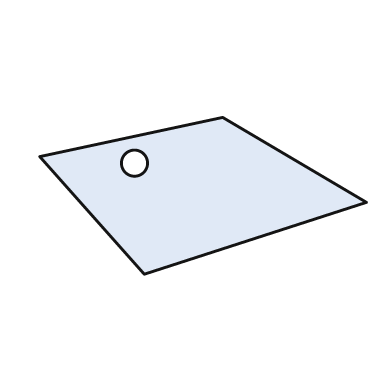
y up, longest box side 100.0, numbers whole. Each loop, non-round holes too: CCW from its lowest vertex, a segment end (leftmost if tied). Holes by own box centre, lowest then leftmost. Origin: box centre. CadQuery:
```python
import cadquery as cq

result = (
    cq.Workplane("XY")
    .moveTo(-18.0, -24.0)
    .lineTo(50.0, -2.0)
    .lineTo(6.0, 24.0)
    .lineTo(-50.0, 12.0)
    .close()
    .moveTo(-21.0, 10.0)
    .circle(4.0)
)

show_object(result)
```